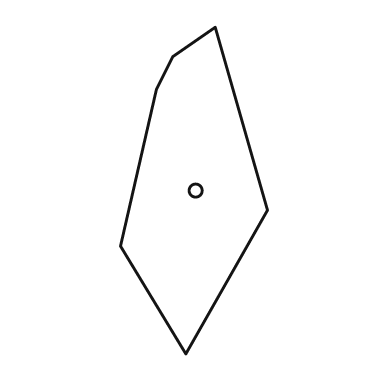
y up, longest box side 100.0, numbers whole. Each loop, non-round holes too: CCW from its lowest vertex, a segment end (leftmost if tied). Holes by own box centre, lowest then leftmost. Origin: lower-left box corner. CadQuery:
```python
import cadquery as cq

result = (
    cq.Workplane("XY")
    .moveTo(20.0, 0.0)
    .lineTo(45.0, 44.0)
    .lineTo(29.0, 100.0)
    .lineTo(16.0, 91.0)
    .lineTo(11.0, 81.0)
    .lineTo(0.0, 33.0)
    .close()
    .moveTo(23.0, 50.0)
    .circle(2.0)
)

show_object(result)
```